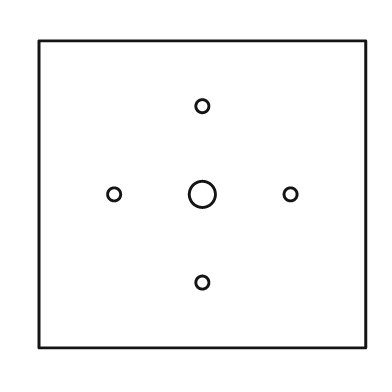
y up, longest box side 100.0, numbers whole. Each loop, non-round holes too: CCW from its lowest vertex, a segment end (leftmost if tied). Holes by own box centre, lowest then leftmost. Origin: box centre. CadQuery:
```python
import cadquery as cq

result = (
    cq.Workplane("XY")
    .moveTo(-50.0, -47.0)
    .lineTo(50.0, -47.0)
    .lineTo(50.0, 47.0)
    .lineTo(-50.0, 47.0)
    .close()
    .moveTo(0.0, -27.0)
    .circle(2.0)
    .moveTo(-27.0, 0.0)
    .circle(2.0)
    .moveTo(0.0, 0.0)
    .circle(4.0)
    .moveTo(27.0, 0.0)
    .circle(2.0)
    .moveTo(0.0, 27.0)
    .circle(2.0)
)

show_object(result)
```